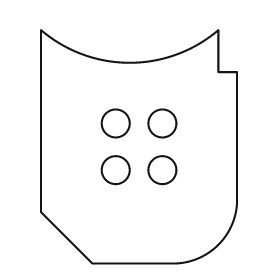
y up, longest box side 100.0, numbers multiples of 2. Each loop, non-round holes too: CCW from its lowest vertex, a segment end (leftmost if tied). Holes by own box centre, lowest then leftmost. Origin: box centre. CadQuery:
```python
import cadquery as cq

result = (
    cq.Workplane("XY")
    .moveTo(-20.0, -50.0)
    .lineTo(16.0, -50.0)
    .threePointArc((34.0, -42.0), (42.0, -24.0))
    .lineTo(42.0, 32.0)
    .lineTo(34.0, 32.0)
    .lineTo(34.0, 50.0)
    .threePointArc((-4.0, 36.0), (-42.0, 50.0))
    .lineTo(-42.0, -28.0)
    .close()
    .moveTo(-10.0, -10.0)
    .circle(6.0)
    .moveTo(10.0, -10.0)
    .circle(6.0)
    .moveTo(-10.0, 10.0)
    .circle(6.0)
    .moveTo(10.0, 10.0)
    .circle(6.0)
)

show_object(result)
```